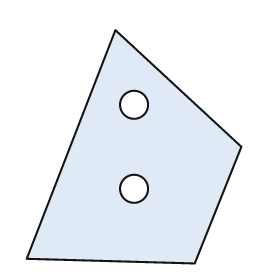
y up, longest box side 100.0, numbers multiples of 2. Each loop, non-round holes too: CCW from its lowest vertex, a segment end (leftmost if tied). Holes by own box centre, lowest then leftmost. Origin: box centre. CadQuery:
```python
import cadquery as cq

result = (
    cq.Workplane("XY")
    .moveTo(26.0, -50.0)
    .lineTo(46.0, 0.0)
    .lineTo(-8.0, 50.0)
    .lineTo(-46.0, -48.0)
    .close()
    .moveTo(0.0, -18.0)
    .circle(6.0)
    .moveTo(0.0, 18.0)
    .circle(6.0)
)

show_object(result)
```